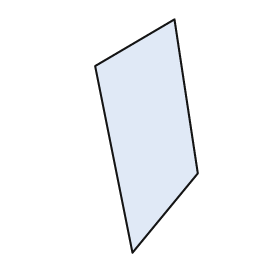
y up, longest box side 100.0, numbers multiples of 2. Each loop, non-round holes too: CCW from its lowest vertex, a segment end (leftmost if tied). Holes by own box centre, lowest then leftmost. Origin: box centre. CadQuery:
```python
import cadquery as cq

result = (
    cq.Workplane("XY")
    .moveTo(-6.0, -50.0)
    .lineTo(22.0, -16.0)
    .lineTo(12.0, 50.0)
    .lineTo(-22.0, 30.0)
    .close()
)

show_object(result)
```